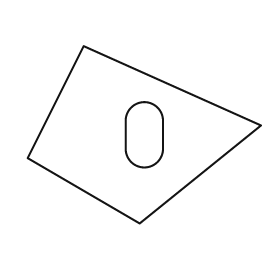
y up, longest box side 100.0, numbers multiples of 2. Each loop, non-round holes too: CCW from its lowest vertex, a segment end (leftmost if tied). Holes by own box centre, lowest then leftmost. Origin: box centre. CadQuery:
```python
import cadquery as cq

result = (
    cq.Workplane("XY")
    .moveTo(-2.0, -38.0)
    .lineTo(50.0, 4.0)
    .lineTo(-26.0, 38.0)
    .lineTo(-50.0, -10.0)
    .close()
    .moveTo(-8.0, -6.0)
    .threePointArc((0.0, -14.0), (8.0, -6.0))
    .lineTo(8.0, 6.0)
    .threePointArc((0.0, 14.0), (-8.0, 6.0))
    .close()
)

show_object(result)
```